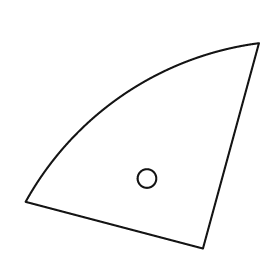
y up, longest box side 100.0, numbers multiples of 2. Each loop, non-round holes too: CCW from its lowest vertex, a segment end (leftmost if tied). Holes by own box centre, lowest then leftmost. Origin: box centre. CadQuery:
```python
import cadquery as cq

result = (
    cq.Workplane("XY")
    .moveTo(26.0, -44.0)
    .lineTo(50.0, 44.0)
    .threePointArc((-8.0, 22.0), (-50.0, -24.0))
    .close()
    .moveTo(2.0, -14.0)
    .circle(4.0)
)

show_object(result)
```